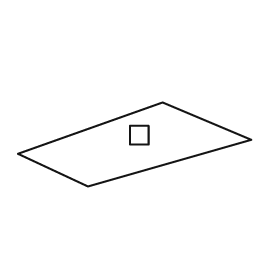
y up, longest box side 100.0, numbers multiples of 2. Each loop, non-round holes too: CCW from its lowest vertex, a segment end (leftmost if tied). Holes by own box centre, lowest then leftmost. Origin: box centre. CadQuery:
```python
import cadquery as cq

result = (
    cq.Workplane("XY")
    .moveTo(-20.0, -18.0)
    .lineTo(50.0, 2.0)
    .lineTo(12.0, 18.0)
    .lineTo(-50.0, -4.0)
    .close()
    .moveTo(-2.0, 0.0)
    .lineTo(6.0, 0.0)
    .lineTo(6.0, 8.0)
    .lineTo(-2.0, 8.0)
    .close()
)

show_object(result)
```